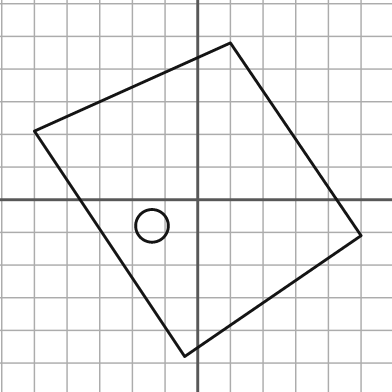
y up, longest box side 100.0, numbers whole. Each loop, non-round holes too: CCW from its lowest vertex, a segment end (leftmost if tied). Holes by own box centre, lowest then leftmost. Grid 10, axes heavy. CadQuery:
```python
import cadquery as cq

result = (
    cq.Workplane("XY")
    .moveTo(-4.0, -48.0)
    .lineTo(50.0, -11.0)
    .lineTo(10.0, 48.0)
    .lineTo(-50.0, 21.0)
    .close()
    .moveTo(-14.0, -8.0)
    .circle(5.0)
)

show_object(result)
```